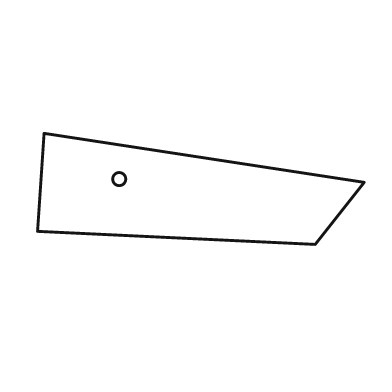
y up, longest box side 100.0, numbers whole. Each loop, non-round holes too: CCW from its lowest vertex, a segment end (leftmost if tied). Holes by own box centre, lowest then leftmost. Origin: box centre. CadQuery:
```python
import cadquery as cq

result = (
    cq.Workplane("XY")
    .moveTo(35.0, -17.0)
    .lineTo(50.0, 2.0)
    .lineTo(-48.0, 17.0)
    .lineTo(-50.0, -13.0)
    .close()
    .moveTo(-25.0, 3.0)
    .circle(2.0)
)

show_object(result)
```